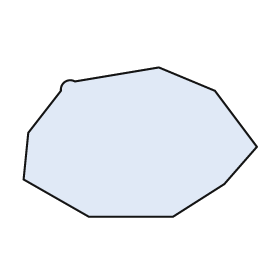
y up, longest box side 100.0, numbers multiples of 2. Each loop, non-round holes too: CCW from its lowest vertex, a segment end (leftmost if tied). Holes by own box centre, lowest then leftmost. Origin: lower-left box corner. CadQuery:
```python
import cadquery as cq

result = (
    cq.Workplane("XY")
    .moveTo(28.0, 0.0)
    .lineTo(64.0, 0.0)
    .lineTo(86.0, 14.0)
    .lineTo(100.0, 30.0)
    .lineTo(82.0, 54.0)
    .lineTo(58.0, 64.0)
    .lineTo(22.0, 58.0)
    .threePointArc((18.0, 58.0), (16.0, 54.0))
    .lineTo(2.0, 36.0)
    .lineTo(0.0, 16.0)
    .close()
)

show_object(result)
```